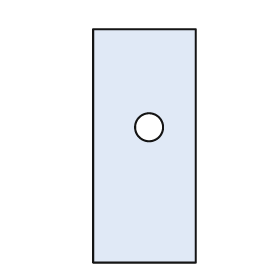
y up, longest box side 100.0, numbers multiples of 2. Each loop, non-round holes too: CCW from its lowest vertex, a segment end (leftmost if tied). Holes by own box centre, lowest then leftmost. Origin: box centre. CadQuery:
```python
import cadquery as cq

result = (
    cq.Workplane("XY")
    .moveTo(-22.0, -50.0)
    .lineTo(22.0, -50.0)
    .lineTo(22.0, 50.0)
    .lineTo(-22.0, 50.0)
    .close()
    .moveTo(2.0, 8.0)
    .circle(6.0)
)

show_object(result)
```